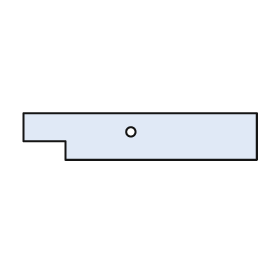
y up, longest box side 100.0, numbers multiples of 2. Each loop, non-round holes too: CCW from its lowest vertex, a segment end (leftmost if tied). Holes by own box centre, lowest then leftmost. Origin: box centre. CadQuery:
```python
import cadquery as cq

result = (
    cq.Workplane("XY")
    .moveTo(-32.0, -10.0)
    .lineTo(50.0, -10.0)
    .lineTo(50.0, 10.0)
    .lineTo(-50.0, 10.0)
    .lineTo(-50.0, -2.0)
    .lineTo(-32.0, -2.0)
    .close()
    .moveTo(-4.0, 2.0)
    .circle(2.0)
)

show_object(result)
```